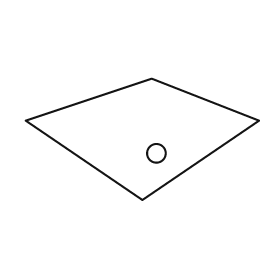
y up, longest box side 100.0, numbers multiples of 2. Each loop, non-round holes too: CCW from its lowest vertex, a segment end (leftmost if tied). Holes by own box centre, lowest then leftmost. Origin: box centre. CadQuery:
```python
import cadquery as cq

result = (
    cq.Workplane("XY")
    .moveTo(0.0, -26.0)
    .lineTo(50.0, 8.0)
    .lineTo(4.0, 26.0)
    .lineTo(-50.0, 8.0)
    .close()
    .moveTo(6.0, -6.0)
    .circle(4.0)
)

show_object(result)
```